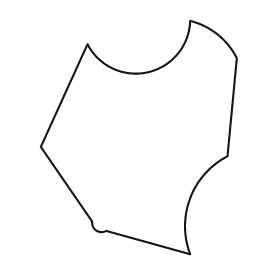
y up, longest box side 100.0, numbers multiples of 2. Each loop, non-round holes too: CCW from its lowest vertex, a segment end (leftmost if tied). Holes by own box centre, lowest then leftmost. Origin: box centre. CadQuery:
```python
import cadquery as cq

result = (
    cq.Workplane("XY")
    .moveTo(22.0, -50.0)
    .threePointArc((22.0, -26.0), (38.0, -8.0))
    .lineTo(42.0, 34.0)
    .threePointArc((34.0, 44.0), (22.0, 50.0))
    .threePointArc((4.0, 28.0), (-22.0, 40.0))
    .lineTo(-42.0, -4.0)
    .lineTo(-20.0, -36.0)
    .threePointArc((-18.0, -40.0), (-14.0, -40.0))
    .close()
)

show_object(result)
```